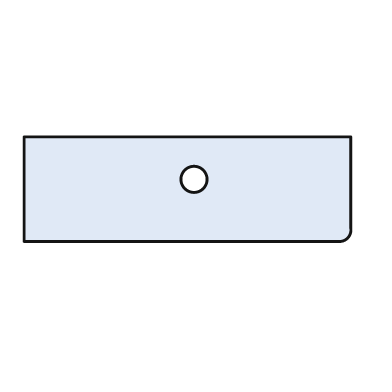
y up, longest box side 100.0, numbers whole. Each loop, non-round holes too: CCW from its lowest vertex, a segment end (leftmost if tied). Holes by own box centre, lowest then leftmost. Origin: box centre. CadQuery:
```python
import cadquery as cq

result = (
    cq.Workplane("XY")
    .moveTo(-50.0, -16.0)
    .lineTo(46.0, -16.0)
    .threePointArc((49.0, -15.0), (50.0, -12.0))
    .lineTo(50.0, 16.0)
    .lineTo(-50.0, 16.0)
    .close()
    .moveTo(2.0, 3.0)
    .circle(4.0)
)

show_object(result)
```